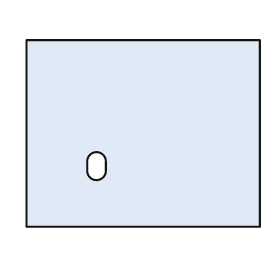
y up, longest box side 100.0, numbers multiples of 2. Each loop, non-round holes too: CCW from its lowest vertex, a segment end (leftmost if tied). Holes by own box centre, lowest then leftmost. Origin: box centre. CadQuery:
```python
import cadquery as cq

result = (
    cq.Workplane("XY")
    .moveTo(-50.0, -40.0)
    .lineTo(50.0, -40.0)
    .lineTo(50.0, 40.0)
    .lineTo(-50.0, 40.0)
    .close()
    .moveTo(-24.0, -16.0)
    .threePointArc((-20.0, -20.0), (-16.0, -16.0))
    .lineTo(-16.0, -12.0)
    .threePointArc((-20.0, -8.0), (-24.0, -12.0))
    .close()
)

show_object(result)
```